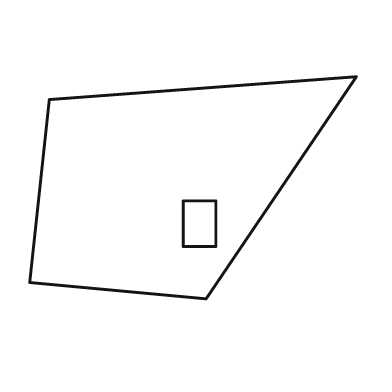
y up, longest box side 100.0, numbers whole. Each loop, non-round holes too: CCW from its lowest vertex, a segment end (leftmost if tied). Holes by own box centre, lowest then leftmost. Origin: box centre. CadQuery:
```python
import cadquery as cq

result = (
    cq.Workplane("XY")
    .moveTo(4.0, -34.0)
    .lineTo(50.0, 34.0)
    .lineTo(-44.0, 27.0)
    .lineTo(-50.0, -29.0)
    .close()
    .moveTo(-3.0, -18.0)
    .lineTo(7.0, -18.0)
    .lineTo(7.0, -4.0)
    .lineTo(-3.0, -4.0)
    .close()
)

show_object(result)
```